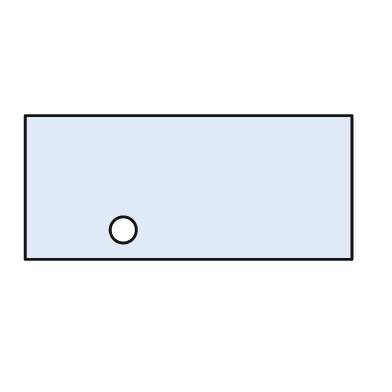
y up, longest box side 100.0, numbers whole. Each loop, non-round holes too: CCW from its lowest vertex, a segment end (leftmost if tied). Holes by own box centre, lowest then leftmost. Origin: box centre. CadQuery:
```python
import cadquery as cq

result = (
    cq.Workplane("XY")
    .moveTo(-50.0, -22.0)
    .lineTo(50.0, -22.0)
    .lineTo(50.0, 22.0)
    .lineTo(-50.0, 22.0)
    .close()
    .moveTo(-20.0, -13.0)
    .circle(4.0)
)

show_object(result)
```